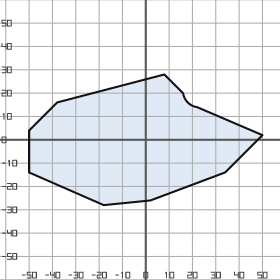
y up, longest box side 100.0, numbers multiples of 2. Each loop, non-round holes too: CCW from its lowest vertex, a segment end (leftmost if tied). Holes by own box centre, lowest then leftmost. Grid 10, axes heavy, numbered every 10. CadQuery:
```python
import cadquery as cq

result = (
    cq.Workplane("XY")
    .moveTo(-18.0, -28.0)
    .lineTo(2.0, -26.0)
    .lineTo(34.0, -14.0)
    .lineTo(50.0, 2.0)
    .lineTo(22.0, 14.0)
    .threePointArc((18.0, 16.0), (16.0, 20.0))
    .lineTo(8.0, 28.0)
    .lineTo(-38.0, 16.0)
    .lineTo(-50.0, 4.0)
    .lineTo(-50.0, -14.0)
    .close()
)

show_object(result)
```